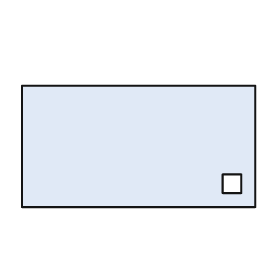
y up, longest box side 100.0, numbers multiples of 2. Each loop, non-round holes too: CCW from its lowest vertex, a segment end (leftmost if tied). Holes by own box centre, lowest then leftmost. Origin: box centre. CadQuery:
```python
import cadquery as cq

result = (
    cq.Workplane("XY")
    .moveTo(-50.0, -26.0)
    .lineTo(50.0, -26.0)
    .lineTo(50.0, 26.0)
    .lineTo(-50.0, 26.0)
    .close()
    .moveTo(36.0, -20.0)
    .lineTo(44.0, -20.0)
    .lineTo(44.0, -12.0)
    .lineTo(36.0, -12.0)
    .close()
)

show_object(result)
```